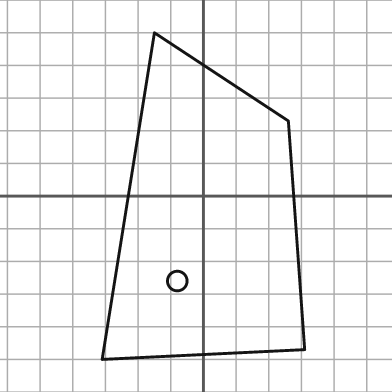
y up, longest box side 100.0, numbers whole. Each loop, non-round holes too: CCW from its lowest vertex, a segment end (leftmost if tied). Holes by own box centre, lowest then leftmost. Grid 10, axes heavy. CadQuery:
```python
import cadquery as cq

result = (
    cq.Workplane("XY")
    .moveTo(-31.0, -50.0)
    .lineTo(31.0, -47.0)
    .lineTo(26.0, 23.0)
    .lineTo(-15.0, 50.0)
    .close()
    .moveTo(-8.0, -26.0)
    .circle(3.0)
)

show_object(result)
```